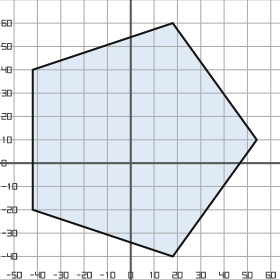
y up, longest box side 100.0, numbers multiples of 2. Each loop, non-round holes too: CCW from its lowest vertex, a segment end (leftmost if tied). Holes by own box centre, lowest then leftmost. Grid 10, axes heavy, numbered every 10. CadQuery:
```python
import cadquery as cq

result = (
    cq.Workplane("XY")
    .moveTo(18.0, -40.0)
    .lineTo(54.0, 10.0)
    .lineTo(18.0, 60.0)
    .lineTo(-42.0, 40.0)
    .lineTo(-42.0, -20.0)
    .close()
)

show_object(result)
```